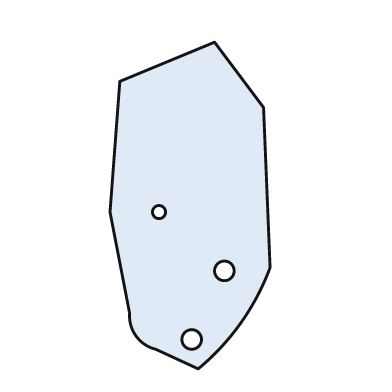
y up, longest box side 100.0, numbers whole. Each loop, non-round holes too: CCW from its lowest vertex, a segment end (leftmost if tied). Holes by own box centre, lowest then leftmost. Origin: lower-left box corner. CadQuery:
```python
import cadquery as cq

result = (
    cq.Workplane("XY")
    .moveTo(27.0, 0.0)
    .threePointArc((40.0, 14.0), (49.0, 31.0))
    .lineTo(47.0, 80.0)
    .lineTo(32.0, 100.0)
    .lineTo(3.0, 88.0)
    .lineTo(0.0, 48.0)
    .lineTo(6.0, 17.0)
    .threePointArc((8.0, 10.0), (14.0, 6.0))
    .close()
    .moveTo(25.0, 9.0)
    .circle(3.0)
    .moveTo(35.0, 30.0)
    .circle(3.0)
    .moveTo(15.0, 48.0)
    .circle(2.0)
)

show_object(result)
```